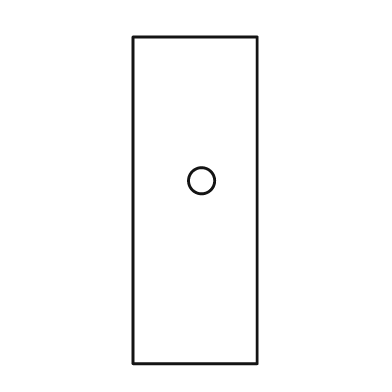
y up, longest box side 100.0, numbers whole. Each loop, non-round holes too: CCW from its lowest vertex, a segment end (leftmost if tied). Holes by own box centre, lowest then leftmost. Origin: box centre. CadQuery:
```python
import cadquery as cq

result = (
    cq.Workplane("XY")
    .moveTo(-19.0, -50.0)
    .lineTo(19.0, -50.0)
    .lineTo(19.0, 50.0)
    .lineTo(-19.0, 50.0)
    .close()
    .moveTo(2.0, 6.0)
    .circle(4.0)
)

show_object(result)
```